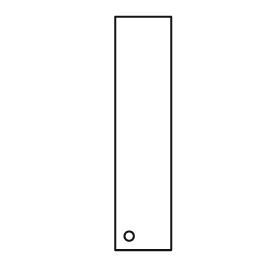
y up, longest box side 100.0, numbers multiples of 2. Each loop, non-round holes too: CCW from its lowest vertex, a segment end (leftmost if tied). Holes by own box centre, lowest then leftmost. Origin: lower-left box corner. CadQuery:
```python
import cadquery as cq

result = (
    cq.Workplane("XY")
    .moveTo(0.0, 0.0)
    .lineTo(24.0, 0.0)
    .lineTo(24.0, 100.0)
    .lineTo(0.0, 100.0)
    .close()
    .moveTo(6.0, 6.0)
    .circle(2.0)
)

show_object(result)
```